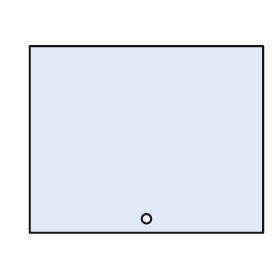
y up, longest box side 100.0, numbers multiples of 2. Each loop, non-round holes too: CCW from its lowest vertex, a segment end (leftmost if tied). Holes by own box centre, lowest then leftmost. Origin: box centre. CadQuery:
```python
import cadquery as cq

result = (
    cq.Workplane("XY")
    .moveTo(-50.0, -40.0)
    .lineTo(50.0, -40.0)
    .lineTo(50.0, 40.0)
    .lineTo(-50.0, 40.0)
    .close()
    .moveTo(0.0, -34.0)
    .circle(2.0)
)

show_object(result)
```